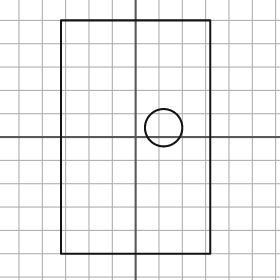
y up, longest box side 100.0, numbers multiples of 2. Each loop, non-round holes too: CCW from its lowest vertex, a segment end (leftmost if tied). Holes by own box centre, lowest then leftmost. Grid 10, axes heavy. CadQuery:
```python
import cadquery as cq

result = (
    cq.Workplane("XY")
    .moveTo(-32.0, -50.0)
    .lineTo(32.0, -50.0)
    .lineTo(32.0, 50.0)
    .lineTo(-32.0, 50.0)
    .close()
    .moveTo(12.0, 4.0)
    .circle(8.0)
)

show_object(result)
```